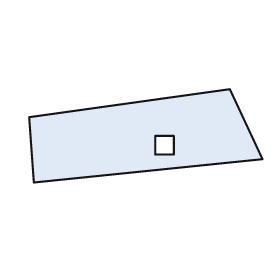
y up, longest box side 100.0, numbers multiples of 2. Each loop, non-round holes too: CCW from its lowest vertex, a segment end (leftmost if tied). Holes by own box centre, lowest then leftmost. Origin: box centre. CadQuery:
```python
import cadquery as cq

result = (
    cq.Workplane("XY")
    .moveTo(-48.0, -20.0)
    .lineTo(50.0, -10.0)
    .lineTo(36.0, 20.0)
    .lineTo(-50.0, 8.0)
    .close()
    .moveTo(4.0, -8.0)
    .lineTo(12.0, -8.0)
    .lineTo(12.0, 0.0)
    .lineTo(4.0, 0.0)
    .close()
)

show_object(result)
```